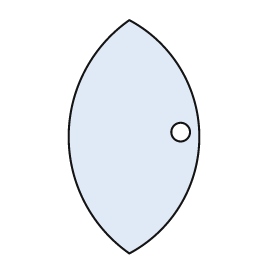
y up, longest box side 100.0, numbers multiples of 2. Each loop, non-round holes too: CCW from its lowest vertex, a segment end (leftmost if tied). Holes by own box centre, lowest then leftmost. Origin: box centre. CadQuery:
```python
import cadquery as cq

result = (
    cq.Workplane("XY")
    .moveTo(-2.0, -50.0)
    .threePointArc((28.0, 0.0), (-2.0, 50.0))
    .threePointArc((-28.0, 0.0), (-2.0, -50.0))
    .close()
    .moveTo(20.0, 2.0)
    .circle(4.0)
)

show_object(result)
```